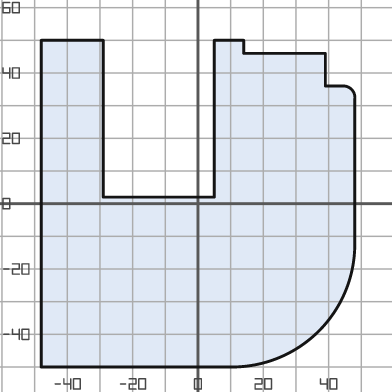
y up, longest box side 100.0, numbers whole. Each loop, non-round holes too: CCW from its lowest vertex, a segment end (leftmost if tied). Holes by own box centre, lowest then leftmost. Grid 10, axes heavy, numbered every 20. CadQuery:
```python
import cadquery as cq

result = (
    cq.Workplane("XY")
    .moveTo(-48.0, -50.0)
    .lineTo(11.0, -50.0)
    .threePointArc((37.0, -39.0), (48.0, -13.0))
    .lineTo(48.0, 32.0)
    .threePointArc((47.0, 35.0), (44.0, 36.0))
    .lineTo(39.0, 36.0)
    .lineTo(39.0, 46.0)
    .lineTo(14.0, 46.0)
    .lineTo(14.0, 50.0)
    .lineTo(5.0, 50.0)
    .lineTo(5.0, 2.0)
    .lineTo(-29.0, 2.0)
    .lineTo(-29.0, 50.0)
    .lineTo(-48.0, 50.0)
    .close()
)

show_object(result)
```